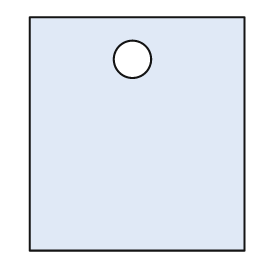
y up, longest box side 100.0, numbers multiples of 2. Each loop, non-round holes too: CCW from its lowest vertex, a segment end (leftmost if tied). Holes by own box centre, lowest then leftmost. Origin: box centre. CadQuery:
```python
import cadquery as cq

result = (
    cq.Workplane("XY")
    .moveTo(-46.0, -50.0)
    .lineTo(46.0, -50.0)
    .lineTo(46.0, 50.0)
    .lineTo(-46.0, 50.0)
    .close()
    .moveTo(-2.0, 32.0)
    .circle(8.0)
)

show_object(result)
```